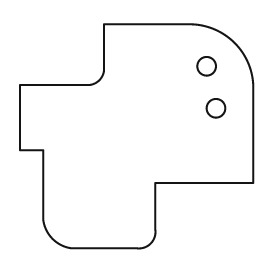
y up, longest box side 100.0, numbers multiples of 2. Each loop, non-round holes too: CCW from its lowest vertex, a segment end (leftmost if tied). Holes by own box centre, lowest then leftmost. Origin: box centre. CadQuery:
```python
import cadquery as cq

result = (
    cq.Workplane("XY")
    .moveTo(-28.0, -48.0)
    .lineTo(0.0, -48.0)
    .threePointArc((6.0, -46.0), (8.0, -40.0))
    .lineTo(8.0, -20.0)
    .lineTo(50.0, -20.0)
    .lineTo(50.0, 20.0)
    .threePointArc((42.0, 40.0), (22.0, 48.0))
    .lineTo(-14.0, 48.0)
    .lineTo(-14.0, 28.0)
    .threePointArc((-16.0, 24.0), (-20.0, 22.0))
    .lineTo(-50.0, 22.0)
    .lineTo(-50.0, -6.0)
    .lineTo(-40.0, -6.0)
    .lineTo(-40.0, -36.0)
    .threePointArc((-36.0, -44.0), (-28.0, -48.0))
    .close()
    .moveTo(34.0, 12.0)
    .circle(4.0)
    .moveTo(30.0, 30.0)
    .circle(4.0)
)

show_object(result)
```